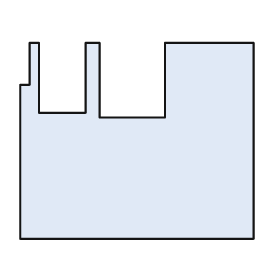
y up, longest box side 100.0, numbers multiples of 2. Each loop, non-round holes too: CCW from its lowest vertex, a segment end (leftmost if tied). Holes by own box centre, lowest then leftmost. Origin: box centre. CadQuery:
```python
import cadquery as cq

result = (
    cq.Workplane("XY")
    .moveTo(-50.0, -42.0)
    .lineTo(50.0, -42.0)
    .lineTo(50.0, 42.0)
    .lineTo(12.0, 42.0)
    .lineTo(12.0, 10.0)
    .lineTo(-16.0, 10.0)
    .lineTo(-16.0, 42.0)
    .lineTo(-22.0, 42.0)
    .lineTo(-22.0, 12.0)
    .lineTo(-42.0, 12.0)
    .lineTo(-42.0, 42.0)
    .lineTo(-46.0, 42.0)
    .lineTo(-46.0, 24.0)
    .lineTo(-50.0, 24.0)
    .close()
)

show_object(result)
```